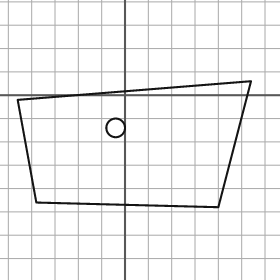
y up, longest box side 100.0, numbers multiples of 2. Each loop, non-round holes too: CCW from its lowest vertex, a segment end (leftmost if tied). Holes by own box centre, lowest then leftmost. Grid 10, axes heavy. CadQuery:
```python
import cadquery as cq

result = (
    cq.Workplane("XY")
    .moveTo(40.0, -48.0)
    .lineTo(54.0, 6.0)
    .lineTo(-46.0, -2.0)
    .lineTo(-38.0, -46.0)
    .close()
    .moveTo(-4.0, -14.0)
    .circle(4.0)
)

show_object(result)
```